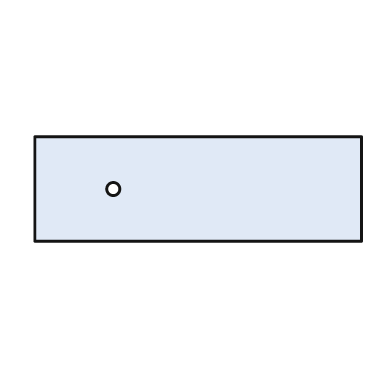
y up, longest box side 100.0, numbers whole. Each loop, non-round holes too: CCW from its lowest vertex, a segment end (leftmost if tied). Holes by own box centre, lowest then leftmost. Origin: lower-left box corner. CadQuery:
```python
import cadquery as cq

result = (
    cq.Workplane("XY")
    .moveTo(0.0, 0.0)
    .lineTo(100.0, 0.0)
    .lineTo(100.0, 32.0)
    .lineTo(0.0, 32.0)
    .close()
    .moveTo(24.0, 16.0)
    .circle(2.0)
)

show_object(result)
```